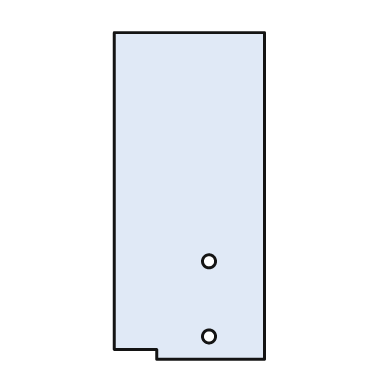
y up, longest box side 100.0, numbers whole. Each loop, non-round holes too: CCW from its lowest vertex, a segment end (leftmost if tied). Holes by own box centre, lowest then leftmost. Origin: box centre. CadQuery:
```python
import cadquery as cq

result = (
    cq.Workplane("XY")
    .moveTo(-10.0, -50.0)
    .lineTo(23.0, -50.0)
    .lineTo(23.0, 50.0)
    .lineTo(-23.0, 50.0)
    .lineTo(-23.0, -47.0)
    .lineTo(-10.0, -47.0)
    .close()
    .moveTo(6.0, -43.0)
    .circle(2.0)
    .moveTo(6.0, -20.0)
    .circle(2.0)
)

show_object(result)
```